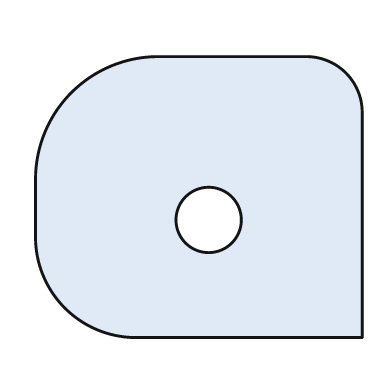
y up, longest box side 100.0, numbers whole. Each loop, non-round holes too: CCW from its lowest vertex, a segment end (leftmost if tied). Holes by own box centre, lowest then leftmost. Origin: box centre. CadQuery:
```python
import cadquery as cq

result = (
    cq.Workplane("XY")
    .moveTo(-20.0, -43.0)
    .lineTo(50.0, -43.0)
    .lineTo(50.0, 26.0)
    .threePointArc((45.0, 38.0), (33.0, 43.0))
    .lineTo(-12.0, 43.0)
    .threePointArc((-39.0, 32.0), (-50.0, 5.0))
    .lineTo(-50.0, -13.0)
    .threePointArc((-41.0, -34.0), (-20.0, -43.0))
    .close()
    .moveTo(3.0, -7.0)
    .circle(10.0)
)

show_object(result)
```